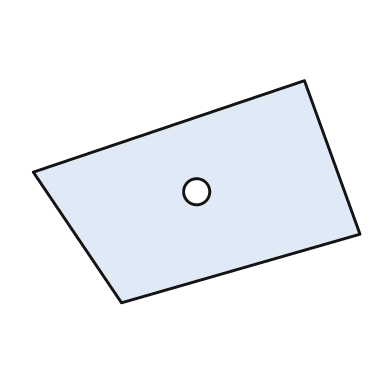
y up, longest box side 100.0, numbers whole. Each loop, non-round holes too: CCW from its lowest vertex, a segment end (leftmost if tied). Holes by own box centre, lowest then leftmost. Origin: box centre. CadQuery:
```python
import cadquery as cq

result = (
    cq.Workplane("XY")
    .moveTo(-23.0, -34.0)
    .lineTo(50.0, -13.0)
    .lineTo(33.0, 34.0)
    .lineTo(-50.0, 6.0)
    .close()
    .moveTo(0.0, 0.0)
    .circle(4.0)
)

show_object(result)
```